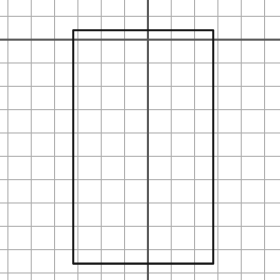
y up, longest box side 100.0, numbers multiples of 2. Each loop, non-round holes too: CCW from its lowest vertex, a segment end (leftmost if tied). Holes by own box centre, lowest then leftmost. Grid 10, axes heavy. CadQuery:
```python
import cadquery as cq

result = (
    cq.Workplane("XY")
    .moveTo(-32.0, -96.0)
    .lineTo(28.0, -96.0)
    .lineTo(28.0, 4.0)
    .lineTo(-32.0, 4.0)
    .close()
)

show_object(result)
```